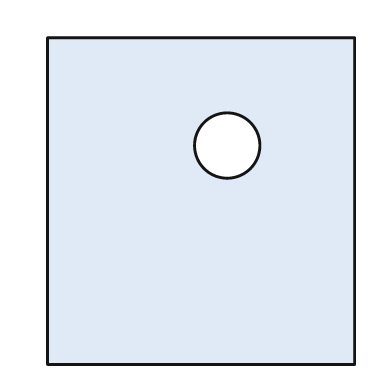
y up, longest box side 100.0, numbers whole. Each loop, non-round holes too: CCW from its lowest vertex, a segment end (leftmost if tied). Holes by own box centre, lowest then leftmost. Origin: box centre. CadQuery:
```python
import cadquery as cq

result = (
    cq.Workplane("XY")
    .moveTo(-47.0, -50.0)
    .lineTo(47.0, -50.0)
    .lineTo(47.0, 50.0)
    .lineTo(-47.0, 50.0)
    .close()
    .moveTo(8.0, 17.0)
    .circle(10.0)
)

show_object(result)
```